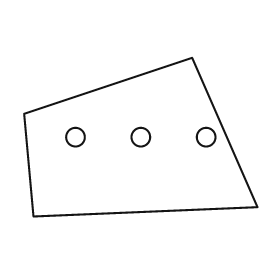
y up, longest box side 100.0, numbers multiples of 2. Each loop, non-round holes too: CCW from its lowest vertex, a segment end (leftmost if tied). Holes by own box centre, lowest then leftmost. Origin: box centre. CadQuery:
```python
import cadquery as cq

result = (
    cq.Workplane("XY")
    .moveTo(-46.0, -34.0)
    .lineTo(50.0, -30.0)
    .lineTo(22.0, 34.0)
    .lineTo(-50.0, 10.0)
    .close()
    .moveTo(-28.0, 0.0)
    .circle(4.0)
    .moveTo(0.0, 0.0)
    .circle(4.0)
    .moveTo(28.0, 0.0)
    .circle(4.0)
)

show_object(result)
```